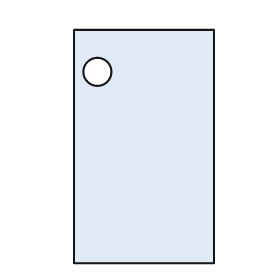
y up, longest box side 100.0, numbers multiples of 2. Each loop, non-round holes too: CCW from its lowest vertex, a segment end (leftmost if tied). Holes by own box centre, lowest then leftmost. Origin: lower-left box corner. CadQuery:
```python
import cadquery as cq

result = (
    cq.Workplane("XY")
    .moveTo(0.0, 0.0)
    .lineTo(60.0, 0.0)
    .lineTo(60.0, 100.0)
    .lineTo(0.0, 100.0)
    .close()
    .moveTo(10.0, 82.0)
    .circle(6.0)
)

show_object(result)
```